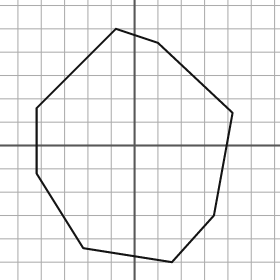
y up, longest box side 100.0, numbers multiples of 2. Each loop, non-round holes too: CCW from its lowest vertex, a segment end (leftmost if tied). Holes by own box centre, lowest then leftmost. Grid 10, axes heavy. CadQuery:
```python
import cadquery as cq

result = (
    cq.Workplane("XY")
    .moveTo(16.0, -50.0)
    .lineTo(34.0, -30.0)
    .lineTo(42.0, 14.0)
    .lineTo(10.0, 44.0)
    .lineTo(-8.0, 50.0)
    .lineTo(-42.0, 16.0)
    .lineTo(-42.0, -12.0)
    .lineTo(-22.0, -44.0)
    .close()
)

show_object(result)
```